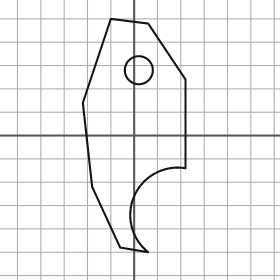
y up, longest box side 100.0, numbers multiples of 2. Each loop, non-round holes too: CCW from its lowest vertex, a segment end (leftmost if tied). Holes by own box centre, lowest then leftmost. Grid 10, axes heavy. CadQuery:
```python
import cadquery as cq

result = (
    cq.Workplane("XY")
    .moveTo(6.0, -50.0)
    .threePointArc((0.0, -26.0), (22.0, -14.0))
    .lineTo(22.0, 24.0)
    .lineTo(6.0, 48.0)
    .lineTo(-10.0, 50.0)
    .lineTo(-22.0, 14.0)
    .lineTo(-18.0, -22.0)
    .lineTo(-6.0, -48.0)
    .close()
    .moveTo(2.0, 28.0)
    .circle(6.0)
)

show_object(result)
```